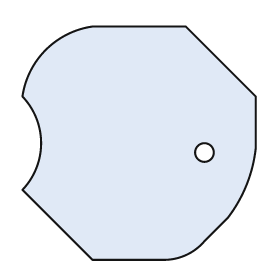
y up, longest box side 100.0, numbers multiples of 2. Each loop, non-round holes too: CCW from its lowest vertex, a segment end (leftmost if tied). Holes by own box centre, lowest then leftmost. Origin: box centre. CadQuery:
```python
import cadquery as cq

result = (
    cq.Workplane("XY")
    .moveTo(-20.0, -50.0)
    .lineTo(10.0, -50.0)
    .threePointArc((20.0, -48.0), (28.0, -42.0))
    .lineTo(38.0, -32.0)
    .threePointArc((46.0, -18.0), (50.0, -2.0))
    .lineTo(50.0, 20.0)
    .lineTo(20.0, 50.0)
    .lineTo(-20.0, 50.0)
    .threePointArc((-40.0, 40.0), (-50.0, 20.0))
    .threePointArc((-42.0, 0.0), (-50.0, -20.0))
    .close()
    .moveTo(28.0, -4.0)
    .circle(4.0)
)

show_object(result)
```